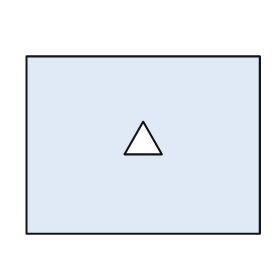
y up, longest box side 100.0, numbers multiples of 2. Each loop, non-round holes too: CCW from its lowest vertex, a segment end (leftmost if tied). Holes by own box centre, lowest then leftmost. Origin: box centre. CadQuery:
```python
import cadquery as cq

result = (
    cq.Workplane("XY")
    .moveTo(-50.0, -38.0)
    .lineTo(50.0, -38.0)
    .lineTo(50.0, 38.0)
    .lineTo(-50.0, 38.0)
    .close()
    .moveTo(-8.0, -4.0)
    .lineTo(8.0, -4.0)
    .lineTo(0.0, 10.0)
    .close()
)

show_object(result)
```